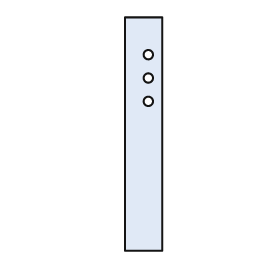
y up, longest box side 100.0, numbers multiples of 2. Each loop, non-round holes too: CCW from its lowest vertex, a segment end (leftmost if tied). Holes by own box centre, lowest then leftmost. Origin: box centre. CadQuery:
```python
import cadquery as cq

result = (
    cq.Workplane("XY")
    .moveTo(-8.0, -50.0)
    .lineTo(8.0, -50.0)
    .lineTo(8.0, 50.0)
    .lineTo(-8.0, 50.0)
    .close()
    .moveTo(2.0, 14.0)
    .circle(2.0)
    .moveTo(2.0, 24.0)
    .circle(2.0)
    .moveTo(2.0, 34.0)
    .circle(2.0)
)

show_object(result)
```